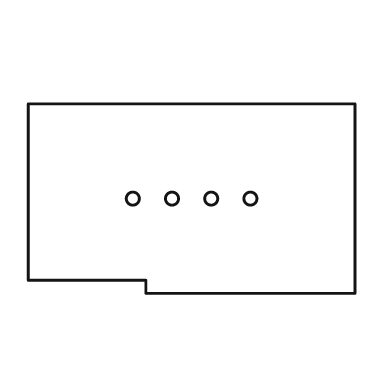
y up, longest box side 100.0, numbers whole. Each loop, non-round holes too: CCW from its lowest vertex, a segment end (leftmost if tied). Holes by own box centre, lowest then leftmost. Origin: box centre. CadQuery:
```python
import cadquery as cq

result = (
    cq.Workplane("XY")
    .moveTo(-14.0, -29.0)
    .lineTo(50.0, -29.0)
    .lineTo(50.0, 29.0)
    .lineTo(-50.0, 29.0)
    .lineTo(-50.0, -25.0)
    .lineTo(-14.0, -25.0)
    .close()
    .moveTo(-18.0, 0.0)
    .circle(2.0)
    .moveTo(-6.0, 0.0)
    .circle(2.0)
    .moveTo(6.0, 0.0)
    .circle(2.0)
    .moveTo(18.0, 0.0)
    .circle(2.0)
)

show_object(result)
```